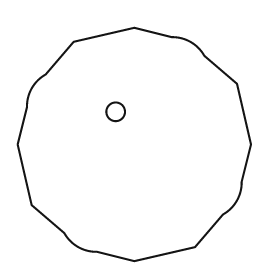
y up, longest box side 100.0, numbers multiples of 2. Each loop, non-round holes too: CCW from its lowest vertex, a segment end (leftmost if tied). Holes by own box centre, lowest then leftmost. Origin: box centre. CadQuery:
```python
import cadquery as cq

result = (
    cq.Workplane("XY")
    .moveTo(0.0, -50.0)
    .lineTo(26.0, -44.0)
    .lineTo(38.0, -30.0)
    .threePointArc((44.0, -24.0), (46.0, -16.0))
    .lineTo(50.0, 0.0)
    .lineTo(44.0, 26.0)
    .lineTo(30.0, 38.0)
    .threePointArc((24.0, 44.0), (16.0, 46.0))
    .lineTo(0.0, 50.0)
    .lineTo(-26.0, 44.0)
    .lineTo(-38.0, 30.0)
    .threePointArc((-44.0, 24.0), (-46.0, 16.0))
    .lineTo(-50.0, 0.0)
    .lineTo(-44.0, -26.0)
    .lineTo(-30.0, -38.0)
    .threePointArc((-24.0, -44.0), (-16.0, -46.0))
    .close()
    .moveTo(-8.0, 14.0)
    .circle(4.0)
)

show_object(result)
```